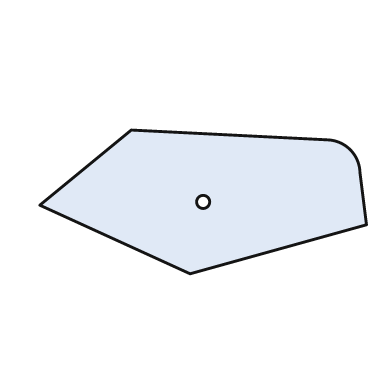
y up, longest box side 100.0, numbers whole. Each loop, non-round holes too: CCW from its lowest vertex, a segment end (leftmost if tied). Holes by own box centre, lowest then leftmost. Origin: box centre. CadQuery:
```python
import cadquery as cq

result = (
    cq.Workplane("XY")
    .moveTo(-4.0, -22.0)
    .lineTo(50.0, -7.0)
    .lineTo(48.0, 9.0)
    .threePointArc((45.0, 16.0), (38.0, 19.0))
    .lineTo(-22.0, 22.0)
    .lineTo(-50.0, -1.0)
    .close()
    .moveTo(0.0, 0.0)
    .circle(2.0)
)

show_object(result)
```